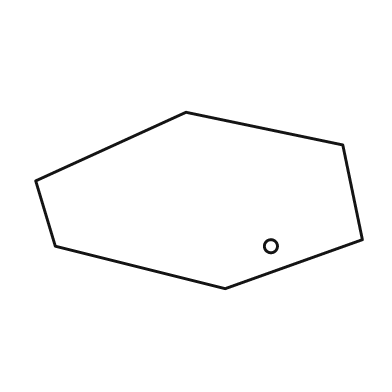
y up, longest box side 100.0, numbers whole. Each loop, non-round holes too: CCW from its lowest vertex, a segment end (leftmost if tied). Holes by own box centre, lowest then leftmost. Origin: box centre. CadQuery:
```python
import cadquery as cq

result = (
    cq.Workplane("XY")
    .moveTo(8.0, -27.0)
    .lineTo(50.0, -12.0)
    .lineTo(44.0, 17.0)
    .lineTo(-4.0, 27.0)
    .lineTo(-50.0, 6.0)
    .lineTo(-44.0, -14.0)
    .close()
    .moveTo(22.0, -14.0)
    .circle(2.0)
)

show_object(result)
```